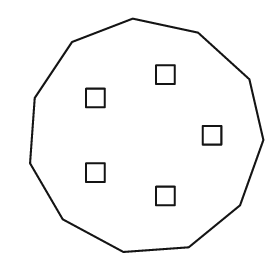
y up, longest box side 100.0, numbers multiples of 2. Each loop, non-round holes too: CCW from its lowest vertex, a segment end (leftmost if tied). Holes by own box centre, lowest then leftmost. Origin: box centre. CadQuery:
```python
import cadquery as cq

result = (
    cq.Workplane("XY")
    .moveTo(-10.0, -50.0)
    .lineTo(18.0, -48.0)
    .lineTo(40.0, -30.0)
    .lineTo(50.0, -2.0)
    .lineTo(44.0, 24.0)
    .lineTo(22.0, 44.0)
    .lineTo(-6.0, 50.0)
    .lineTo(-32.0, 40.0)
    .lineTo(-48.0, 16.0)
    .lineTo(-50.0, -12.0)
    .lineTo(-36.0, -36.0)
    .close()
    .moveTo(4.0, -30.0)
    .lineTo(12.0, -30.0)
    .lineTo(12.0, -22.0)
    .lineTo(4.0, -22.0)
    .close()
    .moveTo(-26.0, -20.0)
    .lineTo(-18.0, -20.0)
    .lineTo(-18.0, -12.0)
    .lineTo(-26.0, -12.0)
    .close()
    .moveTo(24.0, -4.0)
    .lineTo(32.0, -4.0)
    .lineTo(32.0, 4.0)
    .lineTo(24.0, 4.0)
    .close()
    .moveTo(-26.0, 12.0)
    .lineTo(-18.0, 12.0)
    .lineTo(-18.0, 20.0)
    .lineTo(-26.0, 20.0)
    .close()
    .moveTo(4.0, 22.0)
    .lineTo(12.0, 22.0)
    .lineTo(12.0, 30.0)
    .lineTo(4.0, 30.0)
    .close()
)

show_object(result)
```